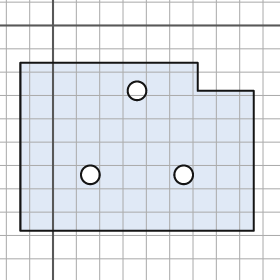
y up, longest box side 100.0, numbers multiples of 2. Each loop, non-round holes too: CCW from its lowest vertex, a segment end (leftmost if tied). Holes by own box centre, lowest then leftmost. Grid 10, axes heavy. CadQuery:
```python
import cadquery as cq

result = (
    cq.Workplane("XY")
    .moveTo(-14.0, -88.0)
    .lineTo(86.0, -88.0)
    .lineTo(86.0, -28.0)
    .lineTo(62.0, -28.0)
    .lineTo(62.0, -16.0)
    .lineTo(-14.0, -16.0)
    .close()
    .moveTo(16.0, -64.0)
    .circle(4.0)
    .moveTo(56.0, -64.0)
    .circle(4.0)
    .moveTo(36.0, -28.0)
    .circle(4.0)
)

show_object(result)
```